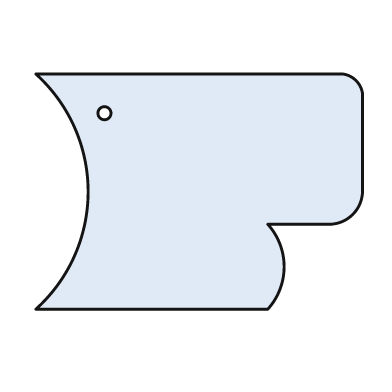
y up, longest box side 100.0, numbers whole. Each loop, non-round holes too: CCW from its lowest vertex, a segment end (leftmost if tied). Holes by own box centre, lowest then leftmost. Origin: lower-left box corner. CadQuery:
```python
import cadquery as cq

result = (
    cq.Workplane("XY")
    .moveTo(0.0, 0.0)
    .lineTo(71.0, 0.0)
    .threePointArc((76.0, 13.0), (71.0, 26.0))
    .lineTo(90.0, 26.0)
    .threePointArc((97.0, 29.0), (100.0, 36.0))
    .lineTo(100.0, 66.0)
    .threePointArc((98.0, 70.0), (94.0, 72.0))
    .lineTo(0.0, 72.0)
    .threePointArc((16.0, 36.0), (0.0, 0.0))
    .close()
    .moveTo(21.0, 60.0)
    .circle(2.0)
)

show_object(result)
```